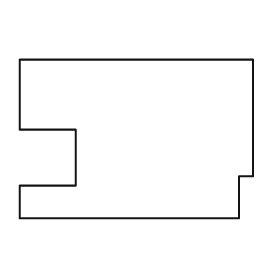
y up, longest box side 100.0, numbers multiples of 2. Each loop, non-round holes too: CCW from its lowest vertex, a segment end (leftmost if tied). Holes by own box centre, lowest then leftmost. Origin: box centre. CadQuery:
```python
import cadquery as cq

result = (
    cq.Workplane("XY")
    .moveTo(-50.0, -34.0)
    .lineTo(44.0, -34.0)
    .lineTo(44.0, -16.0)
    .lineTo(50.0, -16.0)
    .lineTo(50.0, 34.0)
    .lineTo(-50.0, 34.0)
    .lineTo(-50.0, 4.0)
    .lineTo(-26.0, 4.0)
    .lineTo(-26.0, -20.0)
    .lineTo(-50.0, -20.0)
    .close()
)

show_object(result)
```